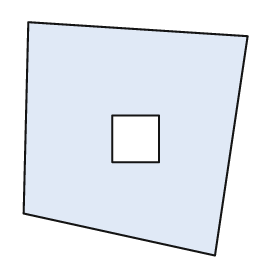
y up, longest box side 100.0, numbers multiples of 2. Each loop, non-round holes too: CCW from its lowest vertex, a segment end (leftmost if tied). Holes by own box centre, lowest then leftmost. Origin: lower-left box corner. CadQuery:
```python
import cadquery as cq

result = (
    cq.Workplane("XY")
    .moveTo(82.0, 0.0)
    .lineTo(96.0, 94.0)
    .lineTo(2.0, 100.0)
    .lineTo(0.0, 18.0)
    .close()
    .moveTo(38.0, 40.0)
    .lineTo(58.0, 40.0)
    .lineTo(58.0, 60.0)
    .lineTo(38.0, 60.0)
    .close()
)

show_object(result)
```